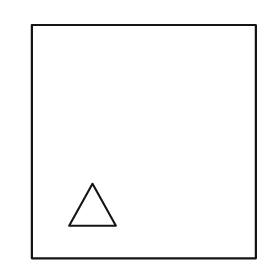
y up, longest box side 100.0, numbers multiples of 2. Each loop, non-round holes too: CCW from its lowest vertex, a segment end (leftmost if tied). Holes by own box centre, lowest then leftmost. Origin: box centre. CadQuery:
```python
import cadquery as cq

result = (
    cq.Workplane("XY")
    .moveTo(-48.0, -50.0)
    .lineTo(48.0, -50.0)
    .lineTo(48.0, 50.0)
    .lineTo(-48.0, 50.0)
    .close()
    .moveTo(-32.0, -36.0)
    .lineTo(-12.0, -36.0)
    .lineTo(-22.0, -18.0)
    .close()
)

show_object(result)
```